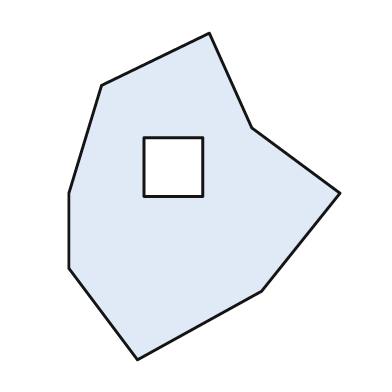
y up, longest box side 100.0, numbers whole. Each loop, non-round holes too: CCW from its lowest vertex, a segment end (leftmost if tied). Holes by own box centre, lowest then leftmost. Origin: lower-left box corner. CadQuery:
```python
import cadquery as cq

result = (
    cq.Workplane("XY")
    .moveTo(21.0, 0.0)
    .lineTo(59.0, 21.0)
    .lineTo(83.0, 51.0)
    .lineTo(56.0, 71.0)
    .lineTo(43.0, 100.0)
    .lineTo(10.0, 84.0)
    .lineTo(0.0, 51.0)
    .lineTo(0.0, 28.0)
    .close()
    .moveTo(23.0, 50.0)
    .lineTo(41.0, 50.0)
    .lineTo(41.0, 68.0)
    .lineTo(23.0, 68.0)
    .close()
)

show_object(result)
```